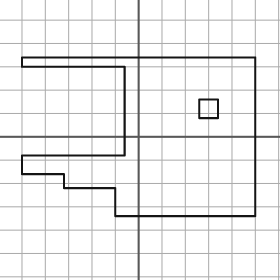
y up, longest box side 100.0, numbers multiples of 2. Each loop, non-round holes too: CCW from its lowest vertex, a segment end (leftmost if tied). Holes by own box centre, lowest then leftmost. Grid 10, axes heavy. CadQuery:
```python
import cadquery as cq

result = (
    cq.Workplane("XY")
    .moveTo(-10.0, -34.0)
    .lineTo(50.0, -34.0)
    .lineTo(50.0, 34.0)
    .lineTo(-50.0, 34.0)
    .lineTo(-50.0, 30.0)
    .lineTo(-6.0, 30.0)
    .lineTo(-6.0, -8.0)
    .lineTo(-50.0, -8.0)
    .lineTo(-50.0, -16.0)
    .lineTo(-32.0, -16.0)
    .lineTo(-32.0, -22.0)
    .lineTo(-10.0, -22.0)
    .close()
    .moveTo(26.0, 8.0)
    .lineTo(34.0, 8.0)
    .lineTo(34.0, 16.0)
    .lineTo(26.0, 16.0)
    .close()
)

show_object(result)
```